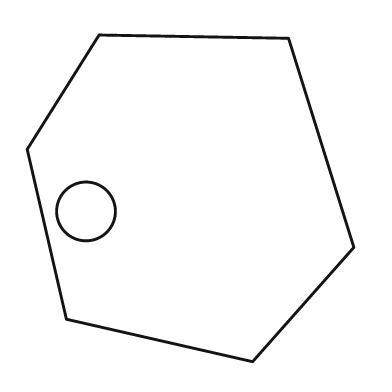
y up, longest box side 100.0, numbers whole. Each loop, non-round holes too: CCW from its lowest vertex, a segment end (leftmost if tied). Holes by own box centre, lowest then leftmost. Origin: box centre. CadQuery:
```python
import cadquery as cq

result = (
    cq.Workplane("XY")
    .moveTo(19.0, -50.0)
    .lineTo(50.0, -15.0)
    .lineTo(30.0, 49.0)
    .lineTo(-28.0, 50.0)
    .lineTo(-50.0, 15.0)
    .lineTo(-38.0, -37.0)
    .close()
    .moveTo(-32.0, -4.0)
    .circle(9.0)
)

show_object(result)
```